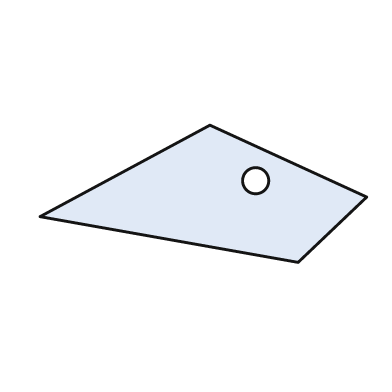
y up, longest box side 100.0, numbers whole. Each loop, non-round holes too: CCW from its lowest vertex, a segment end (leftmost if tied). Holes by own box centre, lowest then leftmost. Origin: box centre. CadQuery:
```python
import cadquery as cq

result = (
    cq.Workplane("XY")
    .moveTo(29.0, -21.0)
    .lineTo(50.0, -1.0)
    .lineTo(2.0, 21.0)
    .lineTo(-50.0, -7.0)
    .close()
    .moveTo(16.0, 4.0)
    .circle(4.0)
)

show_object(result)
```